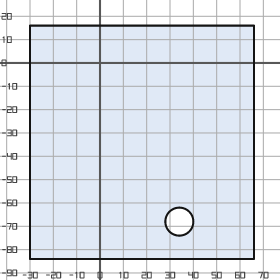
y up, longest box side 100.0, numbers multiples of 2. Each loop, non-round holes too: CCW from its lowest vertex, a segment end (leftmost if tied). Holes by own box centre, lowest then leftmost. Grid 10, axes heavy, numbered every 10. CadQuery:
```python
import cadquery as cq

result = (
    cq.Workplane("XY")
    .moveTo(-30.0, -84.0)
    .lineTo(66.0, -84.0)
    .lineTo(66.0, 16.0)
    .lineTo(-30.0, 16.0)
    .close()
    .moveTo(34.0, -68.0)
    .circle(6.0)
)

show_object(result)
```